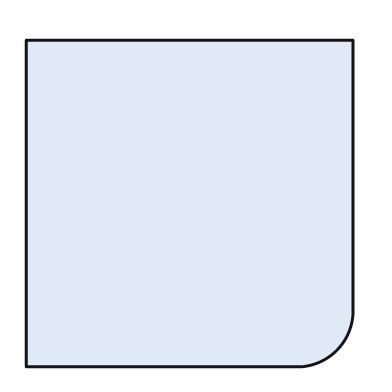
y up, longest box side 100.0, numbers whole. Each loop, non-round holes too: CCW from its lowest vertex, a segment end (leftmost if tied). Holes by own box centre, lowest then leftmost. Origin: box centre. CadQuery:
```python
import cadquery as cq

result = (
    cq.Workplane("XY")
    .moveTo(-50.0, -50.0)
    .lineTo(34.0, -50.0)
    .threePointArc((45.0, -45.0), (50.0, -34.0))
    .lineTo(50.0, 50.0)
    .lineTo(-50.0, 50.0)
    .close()
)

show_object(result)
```